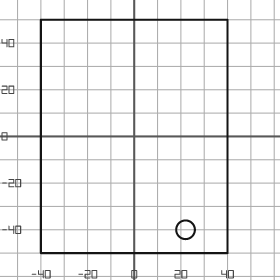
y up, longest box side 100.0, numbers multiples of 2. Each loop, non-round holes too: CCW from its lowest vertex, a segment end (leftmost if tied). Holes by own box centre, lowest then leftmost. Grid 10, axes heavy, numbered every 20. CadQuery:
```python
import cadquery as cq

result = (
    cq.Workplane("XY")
    .moveTo(-40.0, -50.0)
    .lineTo(40.0, -50.0)
    .lineTo(40.0, 50.0)
    .lineTo(-40.0, 50.0)
    .close()
    .moveTo(22.0, -40.0)
    .circle(4.0)
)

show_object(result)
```